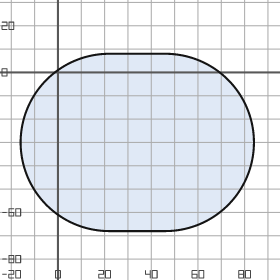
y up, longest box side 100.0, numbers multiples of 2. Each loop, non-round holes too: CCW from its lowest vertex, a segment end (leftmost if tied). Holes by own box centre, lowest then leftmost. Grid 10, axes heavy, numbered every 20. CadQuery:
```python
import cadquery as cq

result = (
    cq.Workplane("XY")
    .moveTo(22.0, -68.0)
    .lineTo(46.0, -68.0)
    .threePointArc((84.0, -30.0), (46.0, 8.0))
    .lineTo(22.0, 8.0)
    .threePointArc((-16.0, -30.0), (22.0, -68.0))
    .close()
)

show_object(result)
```